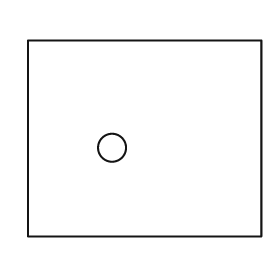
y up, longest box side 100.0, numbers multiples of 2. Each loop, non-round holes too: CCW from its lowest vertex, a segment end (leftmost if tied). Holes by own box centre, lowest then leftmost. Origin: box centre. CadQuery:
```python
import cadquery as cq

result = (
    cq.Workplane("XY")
    .moveTo(-50.0, -42.0)
    .lineTo(50.0, -42.0)
    .lineTo(50.0, 42.0)
    .lineTo(-50.0, 42.0)
    .close()
    .moveTo(-14.0, -4.0)
    .circle(6.0)
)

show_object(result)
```